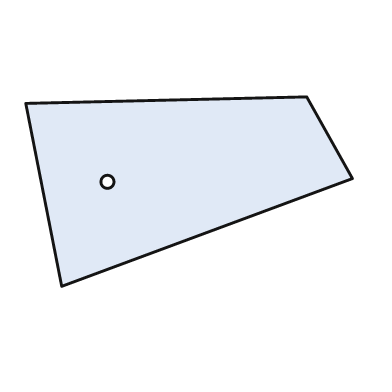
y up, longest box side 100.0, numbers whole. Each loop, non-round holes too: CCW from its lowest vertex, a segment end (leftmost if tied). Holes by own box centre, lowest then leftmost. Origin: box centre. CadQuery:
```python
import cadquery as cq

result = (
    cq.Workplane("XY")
    .moveTo(-39.0, -29.0)
    .lineTo(50.0, 4.0)
    .lineTo(36.0, 29.0)
    .lineTo(-50.0, 27.0)
    .close()
    .moveTo(-25.0, 3.0)
    .circle(2.0)
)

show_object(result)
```